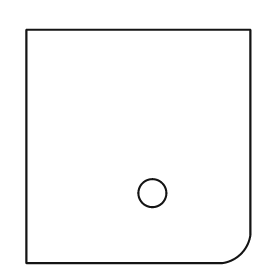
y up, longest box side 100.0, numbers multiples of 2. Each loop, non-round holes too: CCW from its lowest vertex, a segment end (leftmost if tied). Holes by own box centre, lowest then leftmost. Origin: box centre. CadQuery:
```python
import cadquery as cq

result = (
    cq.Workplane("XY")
    .moveTo(-48.0, -50.0)
    .lineTo(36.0, -50.0)
    .threePointArc((44.0, -46.0), (48.0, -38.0))
    .lineTo(48.0, 50.0)
    .lineTo(-48.0, 50.0)
    .close()
    .moveTo(6.0, -20.0)
    .circle(6.0)
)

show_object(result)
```